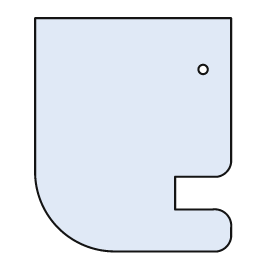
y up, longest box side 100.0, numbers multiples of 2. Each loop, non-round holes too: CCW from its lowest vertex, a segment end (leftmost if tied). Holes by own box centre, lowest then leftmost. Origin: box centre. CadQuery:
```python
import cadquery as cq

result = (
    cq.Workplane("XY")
    .moveTo(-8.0, -50.0)
    .lineTo(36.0, -50.0)
    .threePointArc((40.0, -48.0), (42.0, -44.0))
    .lineTo(42.0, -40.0)
    .threePointArc((40.0, -34.0), (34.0, -32.0))
    .lineTo(18.0, -32.0)
    .lineTo(18.0, -18.0)
    .lineTo(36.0, -18.0)
    .threePointArc((40.0, -16.0), (42.0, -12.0))
    .lineTo(42.0, 50.0)
    .lineTo(-42.0, 50.0)
    .lineTo(-42.0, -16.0)
    .threePointArc((-32.0, -40.0), (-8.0, -50.0))
    .close()
    .moveTo(30.0, 28.0)
    .circle(2.0)
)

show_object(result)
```